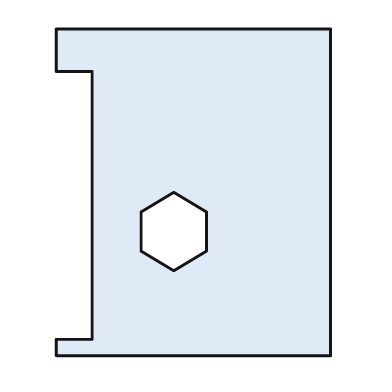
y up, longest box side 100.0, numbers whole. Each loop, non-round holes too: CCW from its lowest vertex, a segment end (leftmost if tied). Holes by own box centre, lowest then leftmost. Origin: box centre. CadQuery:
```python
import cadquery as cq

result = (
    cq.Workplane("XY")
    .moveTo(-42.0, -50.0)
    .lineTo(42.0, -50.0)
    .lineTo(42.0, 50.0)
    .lineTo(-42.0, 50.0)
    .lineTo(-42.0, 37.0)
    .lineTo(-31.0, 37.0)
    .lineTo(-31.0, -45.0)
    .lineTo(-42.0, -45.0)
    .close()
    .moveTo(-6.0, -24.0)
    .lineTo(4.0, -18.0)
    .lineTo(4.0, -6.0)
    .lineTo(-6.0, 0.0)
    .lineTo(-16.0, -6.0)
    .lineTo(-16.0, -18.0)
    .close()
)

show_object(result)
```